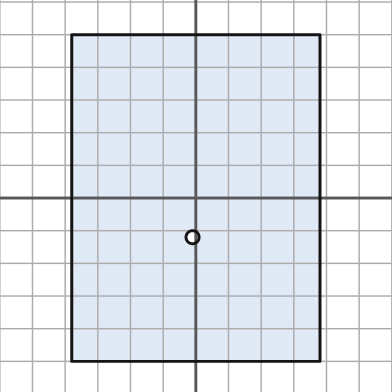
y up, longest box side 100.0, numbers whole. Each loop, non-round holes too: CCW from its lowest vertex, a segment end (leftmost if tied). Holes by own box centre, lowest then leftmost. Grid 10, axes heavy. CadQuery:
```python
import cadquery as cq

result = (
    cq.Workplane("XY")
    .moveTo(-38.0, -50.0)
    .lineTo(38.0, -50.0)
    .lineTo(38.0, 50.0)
    .lineTo(-38.0, 50.0)
    .close()
    .moveTo(-1.0, -12.0)
    .circle(2.0)
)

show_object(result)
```